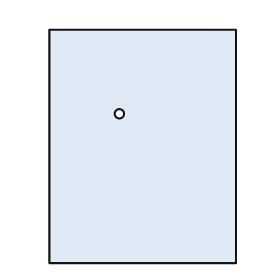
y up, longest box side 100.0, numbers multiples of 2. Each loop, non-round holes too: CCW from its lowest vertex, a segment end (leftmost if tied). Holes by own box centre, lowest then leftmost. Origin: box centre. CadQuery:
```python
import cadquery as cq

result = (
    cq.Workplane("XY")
    .moveTo(-40.0, -50.0)
    .lineTo(40.0, -50.0)
    .lineTo(40.0, 50.0)
    .lineTo(-40.0, 50.0)
    .close()
    .moveTo(-10.0, 14.0)
    .circle(2.0)
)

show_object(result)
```